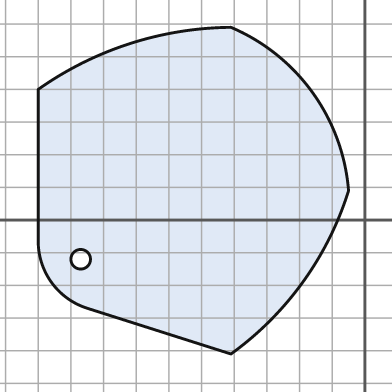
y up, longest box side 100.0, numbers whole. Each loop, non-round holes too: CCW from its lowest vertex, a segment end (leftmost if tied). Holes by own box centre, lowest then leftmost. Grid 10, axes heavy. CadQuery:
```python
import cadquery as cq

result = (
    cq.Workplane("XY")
    .moveTo(-41.0, -41.0)
    .threePointArc((-19.0, -19.0), (-5.0, 9.0))
    .threePointArc((-16.0, 39.0), (-41.0, 59.0))
    .threePointArc((-72.0, 54.0), (-100.0, 40.0))
    .lineTo(-100.0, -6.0)
    .threePointArc((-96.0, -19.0), (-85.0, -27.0))
    .close()
    .moveTo(-87.0, -12.0)
    .circle(3.0)
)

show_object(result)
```